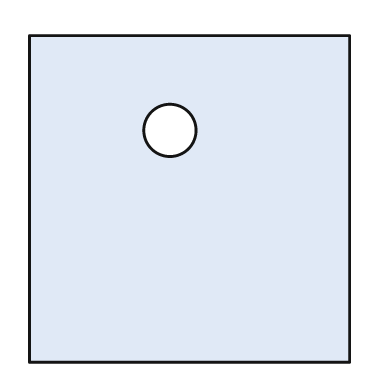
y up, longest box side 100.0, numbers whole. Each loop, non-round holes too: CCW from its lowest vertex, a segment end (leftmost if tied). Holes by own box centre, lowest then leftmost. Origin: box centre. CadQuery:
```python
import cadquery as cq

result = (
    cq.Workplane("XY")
    .moveTo(-49.0, -50.0)
    .lineTo(49.0, -50.0)
    .lineTo(49.0, 50.0)
    .lineTo(-49.0, 50.0)
    .close()
    .moveTo(-6.0, 21.0)
    .circle(8.0)
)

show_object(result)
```